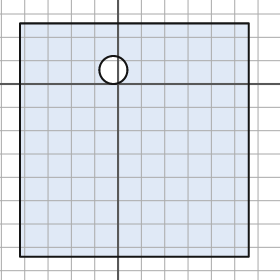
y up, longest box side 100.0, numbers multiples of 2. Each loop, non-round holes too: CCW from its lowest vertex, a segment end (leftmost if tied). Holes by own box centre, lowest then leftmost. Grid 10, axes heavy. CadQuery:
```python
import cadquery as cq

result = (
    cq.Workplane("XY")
    .moveTo(-42.0, -74.0)
    .lineTo(56.0, -74.0)
    .lineTo(56.0, 26.0)
    .lineTo(-42.0, 26.0)
    .close()
    .moveTo(-2.0, 6.0)
    .circle(6.0)
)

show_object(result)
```